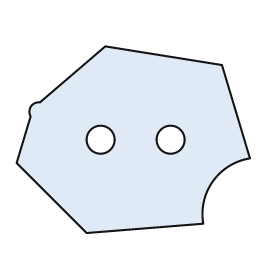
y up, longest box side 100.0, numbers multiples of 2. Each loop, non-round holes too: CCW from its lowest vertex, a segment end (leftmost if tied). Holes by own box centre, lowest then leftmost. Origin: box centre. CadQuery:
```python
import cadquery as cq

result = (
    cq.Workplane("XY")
    .moveTo(-20.0, -40.0)
    .lineTo(30.0, -36.0)
    .threePointArc((34.0, -18.0), (50.0, -8.0))
    .lineTo(38.0, 32.0)
    .lineTo(-12.0, 40.0)
    .lineTo(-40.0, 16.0)
    .threePointArc((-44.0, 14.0), (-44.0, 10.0))
    .lineTo(-50.0, -10.0)
    .close()
    .moveTo(-14.0, 0.0)
    .circle(6.0)
    .moveTo(16.0, 0.0)
    .circle(6.0)
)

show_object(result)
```